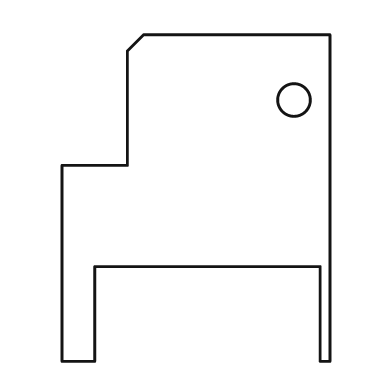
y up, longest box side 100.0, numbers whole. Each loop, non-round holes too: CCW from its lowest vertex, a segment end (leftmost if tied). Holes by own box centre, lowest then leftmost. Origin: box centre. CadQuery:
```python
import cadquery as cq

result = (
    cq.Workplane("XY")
    .moveTo(-41.0, -50.0)
    .lineTo(-31.0, -50.0)
    .lineTo(-31.0, -21.0)
    .lineTo(38.0, -21.0)
    .lineTo(38.0, -50.0)
    .lineTo(41.0, -50.0)
    .lineTo(41.0, 50.0)
    .lineTo(-16.0, 50.0)
    .lineTo(-21.0, 45.0)
    .lineTo(-21.0, 10.0)
    .lineTo(-41.0, 10.0)
    .close()
    .moveTo(30.0, 30.0)
    .circle(5.0)
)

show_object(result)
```